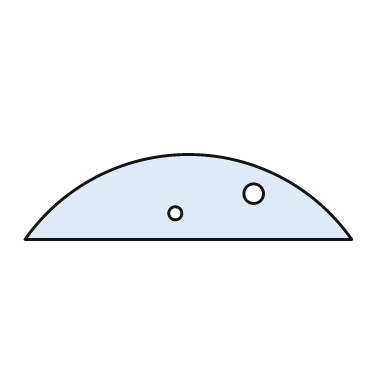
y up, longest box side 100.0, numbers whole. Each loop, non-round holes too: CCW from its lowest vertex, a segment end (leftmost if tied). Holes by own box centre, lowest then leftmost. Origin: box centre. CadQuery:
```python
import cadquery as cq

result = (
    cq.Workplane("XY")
    .moveTo(-50.0, -13.0)
    .lineTo(50.0, -13.0)
    .threePointArc((0.0, 13.0), (-50.0, -13.0))
    .close()
    .moveTo(-4.0, -5.0)
    .circle(2.0)
    .moveTo(20.0, 1.0)
    .circle(3.0)
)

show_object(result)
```